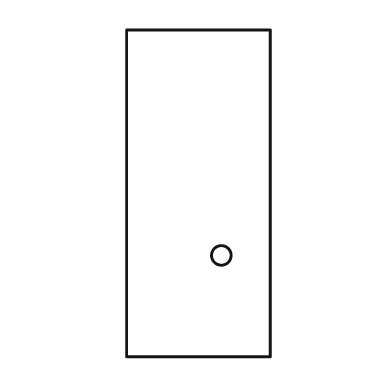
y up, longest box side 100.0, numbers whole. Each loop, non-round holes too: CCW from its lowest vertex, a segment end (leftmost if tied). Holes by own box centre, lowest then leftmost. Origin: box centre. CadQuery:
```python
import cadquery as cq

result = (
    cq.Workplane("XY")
    .moveTo(-22.0, -50.0)
    .lineTo(22.0, -50.0)
    .lineTo(22.0, 50.0)
    .lineTo(-22.0, 50.0)
    .close()
    .moveTo(7.0, -19.0)
    .circle(3.0)
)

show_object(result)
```